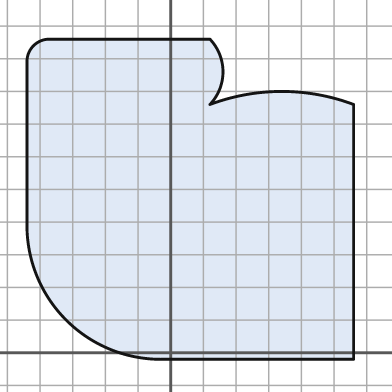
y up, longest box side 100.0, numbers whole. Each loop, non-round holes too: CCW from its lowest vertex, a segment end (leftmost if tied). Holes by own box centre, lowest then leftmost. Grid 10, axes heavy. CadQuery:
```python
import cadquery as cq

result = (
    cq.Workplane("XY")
    .moveTo(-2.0, -2.0)
    .lineTo(56.0, -2.0)
    .lineTo(56.0, 76.0)
    .threePointArc((34.0, 80.0), (12.0, 76.0))
    .threePointArc((16.0, 86.0), (12.0, 96.0))
    .lineTo(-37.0, 96.0)
    .threePointArc((-42.0, 94.0), (-44.0, 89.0))
    .lineTo(-44.0, 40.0)
    .threePointArc((-32.0, 10.0), (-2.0, -2.0))
    .close()
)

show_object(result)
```